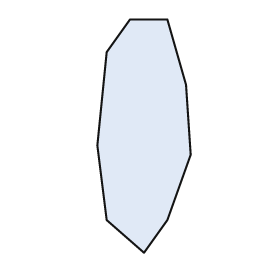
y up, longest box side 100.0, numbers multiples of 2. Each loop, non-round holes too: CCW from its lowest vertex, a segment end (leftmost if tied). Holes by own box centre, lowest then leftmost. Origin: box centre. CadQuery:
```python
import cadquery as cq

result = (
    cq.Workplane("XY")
    .moveTo(0.0, -50.0)
    .lineTo(10.0, -36.0)
    .lineTo(20.0, -8.0)
    .lineTo(18.0, 22.0)
    .lineTo(10.0, 50.0)
    .lineTo(-6.0, 50.0)
    .lineTo(-16.0, 36.0)
    .lineTo(-20.0, -4.0)
    .lineTo(-16.0, -36.0)
    .close()
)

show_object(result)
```